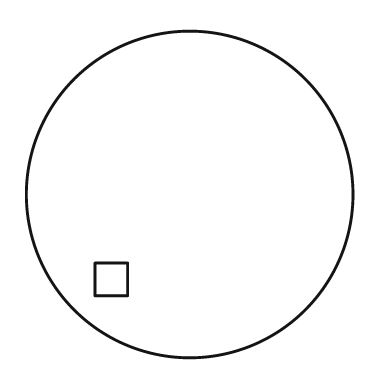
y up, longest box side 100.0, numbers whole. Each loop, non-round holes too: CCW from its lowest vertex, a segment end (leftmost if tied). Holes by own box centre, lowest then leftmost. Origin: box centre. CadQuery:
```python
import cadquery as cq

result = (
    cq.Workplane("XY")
    .moveTo(0.0, 0.0)
    .circle(50.0)
    .moveTo(-29.0, -31.0)
    .lineTo(-19.0, -31.0)
    .lineTo(-19.0, -21.0)
    .lineTo(-29.0, -21.0)
    .close()
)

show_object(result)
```